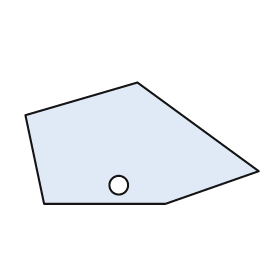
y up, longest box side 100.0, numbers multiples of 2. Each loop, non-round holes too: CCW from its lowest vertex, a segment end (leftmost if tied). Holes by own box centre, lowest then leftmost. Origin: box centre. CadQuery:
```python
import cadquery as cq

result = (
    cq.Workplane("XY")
    .moveTo(-42.0, -26.0)
    .lineTo(10.0, -26.0)
    .lineTo(50.0, -12.0)
    .lineTo(-2.0, 26.0)
    .lineTo(-50.0, 12.0)
    .close()
    .moveTo(-10.0, -18.0)
    .circle(4.0)
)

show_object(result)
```